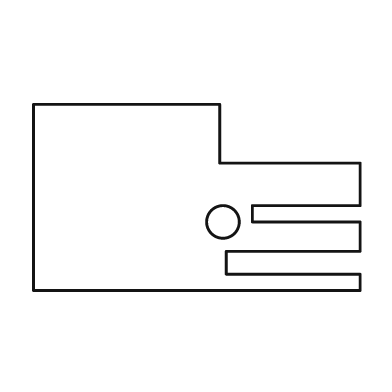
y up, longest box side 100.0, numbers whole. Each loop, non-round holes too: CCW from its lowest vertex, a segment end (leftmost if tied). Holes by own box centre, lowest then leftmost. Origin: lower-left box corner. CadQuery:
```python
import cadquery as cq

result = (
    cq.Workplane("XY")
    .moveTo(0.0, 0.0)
    .lineTo(100.0, 0.0)
    .lineTo(100.0, 5.0)
    .lineTo(59.0, 5.0)
    .lineTo(59.0, 12.0)
    .lineTo(100.0, 12.0)
    .lineTo(100.0, 21.0)
    .lineTo(67.0, 21.0)
    .lineTo(67.0, 26.0)
    .lineTo(100.0, 26.0)
    .lineTo(100.0, 39.0)
    .lineTo(57.0, 39.0)
    .lineTo(57.0, 57.0)
    .lineTo(0.0, 57.0)
    .close()
    .moveTo(58.0, 21.0)
    .circle(5.0)
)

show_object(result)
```